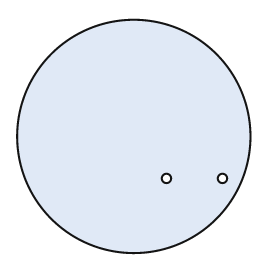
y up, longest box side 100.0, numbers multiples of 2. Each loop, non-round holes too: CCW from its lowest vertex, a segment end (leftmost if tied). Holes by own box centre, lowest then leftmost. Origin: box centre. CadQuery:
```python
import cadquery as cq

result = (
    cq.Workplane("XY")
    .moveTo(0.0, 0.0)
    .circle(50.0)
    .moveTo(14.0, -18.0)
    .circle(2.0)
    .moveTo(38.0, -18.0)
    .circle(2.0)
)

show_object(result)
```